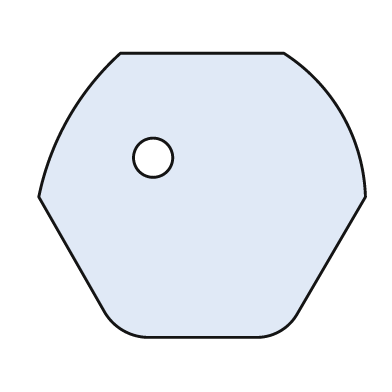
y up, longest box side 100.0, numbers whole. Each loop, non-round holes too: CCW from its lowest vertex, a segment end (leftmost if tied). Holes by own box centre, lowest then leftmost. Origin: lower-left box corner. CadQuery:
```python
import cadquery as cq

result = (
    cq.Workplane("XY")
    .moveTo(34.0, 0.0)
    .lineTo(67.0, 0.0)
    .threePointArc((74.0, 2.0), (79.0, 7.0))
    .lineTo(100.0, 43.0)
    .threePointArc((93.0, 68.0), (75.0, 87.0))
    .lineTo(25.0, 87.0)
    .threePointArc((9.0, 67.0), (0.0, 43.0))
    .lineTo(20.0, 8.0)
    .threePointArc((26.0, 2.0), (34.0, 0.0))
    .close()
    .moveTo(35.0, 55.0)
    .circle(6.0)
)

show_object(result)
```